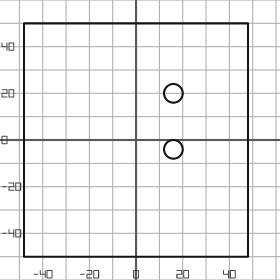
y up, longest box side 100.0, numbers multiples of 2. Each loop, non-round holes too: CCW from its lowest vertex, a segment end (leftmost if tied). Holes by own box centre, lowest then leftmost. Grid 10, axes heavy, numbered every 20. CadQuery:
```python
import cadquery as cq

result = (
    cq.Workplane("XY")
    .moveTo(-48.0, -50.0)
    .lineTo(48.0, -50.0)
    .lineTo(48.0, 50.0)
    .lineTo(-48.0, 50.0)
    .close()
    .moveTo(16.0, -4.0)
    .circle(4.0)
    .moveTo(16.0, 20.0)
    .circle(4.0)
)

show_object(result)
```